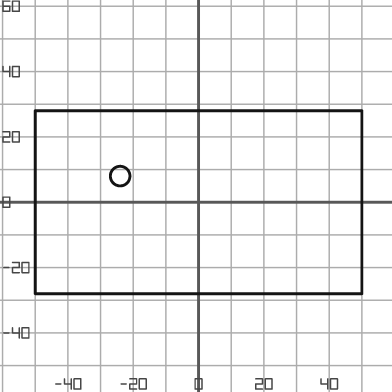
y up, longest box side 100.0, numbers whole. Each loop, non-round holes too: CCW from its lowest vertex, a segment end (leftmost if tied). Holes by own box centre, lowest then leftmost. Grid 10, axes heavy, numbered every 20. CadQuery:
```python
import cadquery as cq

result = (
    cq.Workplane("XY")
    .moveTo(-50.0, -28.0)
    .lineTo(50.0, -28.0)
    .lineTo(50.0, 28.0)
    .lineTo(-50.0, 28.0)
    .close()
    .moveTo(-24.0, 8.0)
    .circle(3.0)
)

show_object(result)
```